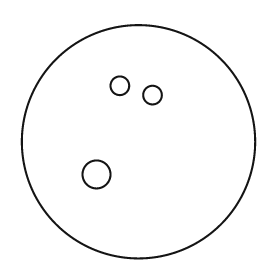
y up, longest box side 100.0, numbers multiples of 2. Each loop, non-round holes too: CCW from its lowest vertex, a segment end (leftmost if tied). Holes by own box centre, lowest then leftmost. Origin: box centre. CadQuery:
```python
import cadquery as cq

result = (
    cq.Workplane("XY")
    .moveTo(0.0, 0.0)
    .circle(50.0)
    .moveTo(-18.0, -14.0)
    .circle(6.0)
    .moveTo(6.0, 20.0)
    .circle(4.0)
    .moveTo(-8.0, 24.0)
    .circle(4.0)
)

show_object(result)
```